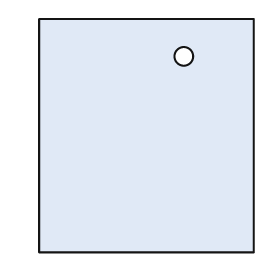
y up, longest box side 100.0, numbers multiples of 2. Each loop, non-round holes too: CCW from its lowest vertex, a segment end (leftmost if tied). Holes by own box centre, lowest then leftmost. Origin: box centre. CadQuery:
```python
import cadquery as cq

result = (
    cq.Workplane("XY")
    .moveTo(-46.0, -50.0)
    .lineTo(46.0, -50.0)
    .lineTo(46.0, 50.0)
    .lineTo(-46.0, 50.0)
    .close()
    .moveTo(16.0, 34.0)
    .circle(4.0)
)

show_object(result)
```